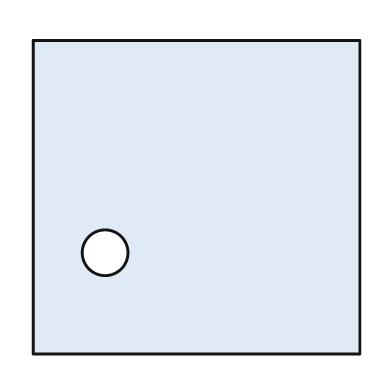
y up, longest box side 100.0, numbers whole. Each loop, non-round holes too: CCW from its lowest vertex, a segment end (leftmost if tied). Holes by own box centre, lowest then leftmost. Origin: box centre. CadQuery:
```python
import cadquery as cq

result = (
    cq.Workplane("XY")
    .moveTo(-50.0, -48.0)
    .lineTo(50.0, -48.0)
    .lineTo(50.0, 48.0)
    .lineTo(-50.0, 48.0)
    .close()
    .moveTo(-28.0, -17.0)
    .circle(7.0)
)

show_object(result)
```